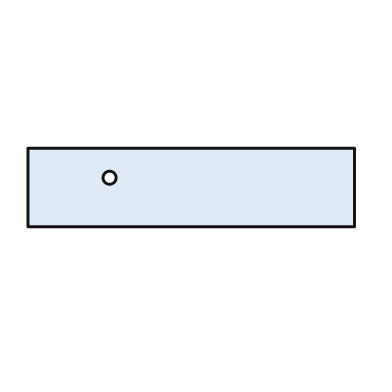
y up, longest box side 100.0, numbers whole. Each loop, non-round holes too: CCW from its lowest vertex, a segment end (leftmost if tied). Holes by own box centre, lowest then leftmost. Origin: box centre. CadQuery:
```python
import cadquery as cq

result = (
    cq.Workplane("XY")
    .moveTo(-50.0, -12.0)
    .lineTo(50.0, -12.0)
    .lineTo(50.0, 12.0)
    .lineTo(-50.0, 12.0)
    .close()
    .moveTo(-25.0, 3.0)
    .circle(2.0)
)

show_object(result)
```